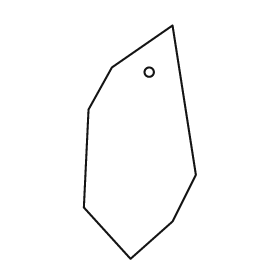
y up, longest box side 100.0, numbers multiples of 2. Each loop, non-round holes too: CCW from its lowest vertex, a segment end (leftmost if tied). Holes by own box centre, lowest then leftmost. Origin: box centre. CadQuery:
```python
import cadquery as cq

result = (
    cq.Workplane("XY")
    .moveTo(-4.0, -50.0)
    .lineTo(14.0, -34.0)
    .lineTo(24.0, -14.0)
    .lineTo(14.0, 50.0)
    .lineTo(-12.0, 32.0)
    .lineTo(-22.0, 14.0)
    .lineTo(-24.0, -28.0)
    .close()
    .moveTo(4.0, 30.0)
    .circle(2.0)
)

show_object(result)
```